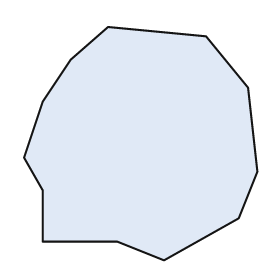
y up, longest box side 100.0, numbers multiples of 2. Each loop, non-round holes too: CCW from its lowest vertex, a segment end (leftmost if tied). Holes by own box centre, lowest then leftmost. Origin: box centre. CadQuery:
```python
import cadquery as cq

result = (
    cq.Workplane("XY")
    .moveTo(10.0, -50.0)
    .lineTo(42.0, -32.0)
    .lineTo(50.0, -12.0)
    .lineTo(46.0, 24.0)
    .lineTo(28.0, 46.0)
    .lineTo(-14.0, 50.0)
    .lineTo(-30.0, 36.0)
    .lineTo(-42.0, 18.0)
    .lineTo(-50.0, -6.0)
    .lineTo(-42.0, -20.0)
    .lineTo(-42.0, -42.0)
    .lineTo(-10.0, -42.0)
    .close()
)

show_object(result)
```